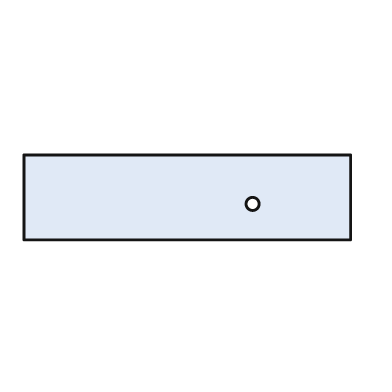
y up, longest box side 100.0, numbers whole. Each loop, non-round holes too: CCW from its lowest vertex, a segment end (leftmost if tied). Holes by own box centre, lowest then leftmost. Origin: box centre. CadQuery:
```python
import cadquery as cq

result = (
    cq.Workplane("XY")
    .moveTo(-50.0, -13.0)
    .lineTo(50.0, -13.0)
    .lineTo(50.0, 13.0)
    .lineTo(-50.0, 13.0)
    .close()
    .moveTo(20.0, -2.0)
    .circle(2.0)
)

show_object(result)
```